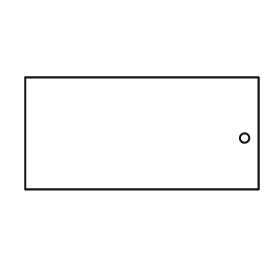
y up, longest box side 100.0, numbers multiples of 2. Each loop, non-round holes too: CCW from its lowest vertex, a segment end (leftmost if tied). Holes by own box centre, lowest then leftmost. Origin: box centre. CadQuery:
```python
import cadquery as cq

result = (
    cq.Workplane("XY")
    .moveTo(-50.0, -24.0)
    .lineTo(50.0, -24.0)
    .lineTo(50.0, 24.0)
    .lineTo(-50.0, 24.0)
    .close()
    .moveTo(44.0, -2.0)
    .circle(2.0)
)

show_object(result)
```